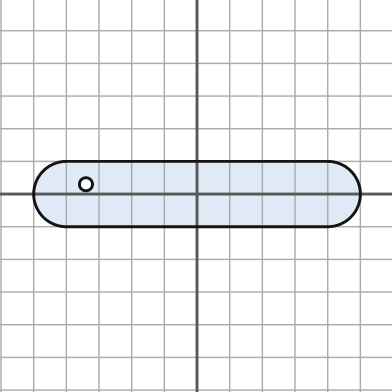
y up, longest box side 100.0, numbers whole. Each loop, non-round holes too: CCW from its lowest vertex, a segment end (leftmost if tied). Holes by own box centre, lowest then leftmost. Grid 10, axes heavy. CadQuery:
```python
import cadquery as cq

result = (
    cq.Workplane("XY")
    .moveTo(-40.0, -10.0)
    .lineTo(40.0, -10.0)
    .threePointArc((50.0, 0.0), (40.0, 10.0))
    .lineTo(-40.0, 10.0)
    .threePointArc((-50.0, 0.0), (-40.0, -10.0))
    .close()
    .moveTo(-34.0, 3.0)
    .circle(2.0)
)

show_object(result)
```